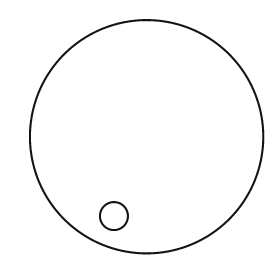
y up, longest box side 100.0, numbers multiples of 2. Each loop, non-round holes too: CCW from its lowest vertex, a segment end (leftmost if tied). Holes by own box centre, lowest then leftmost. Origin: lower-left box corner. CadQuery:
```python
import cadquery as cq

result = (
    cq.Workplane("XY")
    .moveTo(50.0, 50.0)
    .circle(50.0)
    .moveTo(36.0, 16.0)
    .circle(6.0)
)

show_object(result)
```